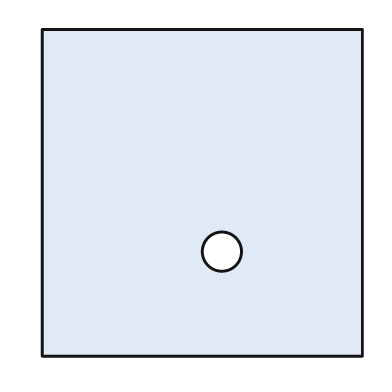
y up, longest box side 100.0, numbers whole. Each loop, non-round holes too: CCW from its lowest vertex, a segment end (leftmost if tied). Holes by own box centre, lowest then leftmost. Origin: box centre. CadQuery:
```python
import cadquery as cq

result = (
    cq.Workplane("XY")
    .moveTo(-49.0, -50.0)
    .lineTo(49.0, -50.0)
    .lineTo(49.0, 50.0)
    .lineTo(-49.0, 50.0)
    .close()
    .moveTo(6.0, -18.0)
    .circle(6.0)
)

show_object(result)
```